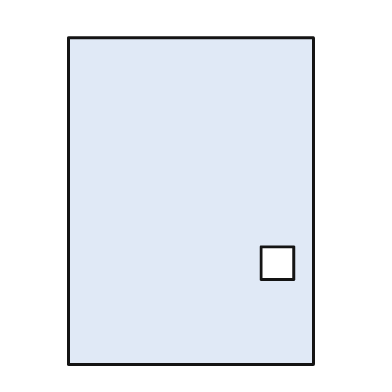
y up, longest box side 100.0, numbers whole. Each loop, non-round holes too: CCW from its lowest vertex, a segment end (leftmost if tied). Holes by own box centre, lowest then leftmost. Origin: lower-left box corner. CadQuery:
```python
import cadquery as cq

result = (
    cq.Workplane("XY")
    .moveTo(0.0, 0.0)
    .lineTo(75.0, 0.0)
    .lineTo(75.0, 100.0)
    .lineTo(0.0, 100.0)
    .close()
    .moveTo(59.0, 26.0)
    .lineTo(69.0, 26.0)
    .lineTo(69.0, 36.0)
    .lineTo(59.0, 36.0)
    .close()
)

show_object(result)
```